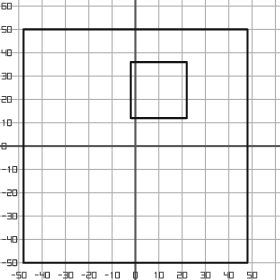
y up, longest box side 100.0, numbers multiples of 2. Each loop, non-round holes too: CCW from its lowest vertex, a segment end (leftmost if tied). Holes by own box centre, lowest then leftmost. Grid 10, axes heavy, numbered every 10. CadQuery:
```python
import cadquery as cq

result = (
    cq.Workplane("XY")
    .moveTo(-48.0, -50.0)
    .lineTo(48.0, -50.0)
    .lineTo(48.0, 50.0)
    .lineTo(-48.0, 50.0)
    .close()
    .moveTo(-2.0, 12.0)
    .lineTo(22.0, 12.0)
    .lineTo(22.0, 36.0)
    .lineTo(-2.0, 36.0)
    .close()
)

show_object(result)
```